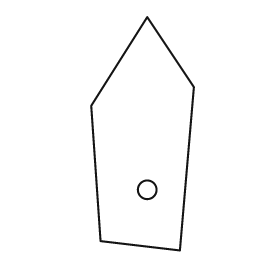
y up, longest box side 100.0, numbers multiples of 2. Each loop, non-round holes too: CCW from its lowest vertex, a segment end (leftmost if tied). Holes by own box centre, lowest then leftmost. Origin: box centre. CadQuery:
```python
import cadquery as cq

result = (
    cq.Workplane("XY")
    .moveTo(16.0, -50.0)
    .lineTo(22.0, 20.0)
    .lineTo(2.0, 50.0)
    .lineTo(-22.0, 12.0)
    .lineTo(-18.0, -46.0)
    .close()
    .moveTo(2.0, -24.0)
    .circle(4.0)
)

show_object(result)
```